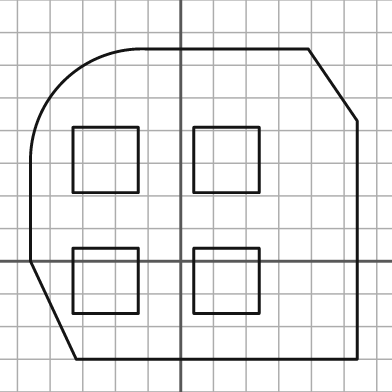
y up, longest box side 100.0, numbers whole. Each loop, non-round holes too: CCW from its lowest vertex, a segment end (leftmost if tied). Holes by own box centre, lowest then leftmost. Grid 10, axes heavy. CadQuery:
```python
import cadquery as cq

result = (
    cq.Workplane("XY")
    .moveTo(-32.0, -30.0)
    .lineTo(54.0, -30.0)
    .lineTo(54.0, 43.0)
    .lineTo(39.0, 65.0)
    .lineTo(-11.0, 65.0)
    .threePointArc((-36.0, 55.0), (-46.0, 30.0))
    .lineTo(-46.0, 0.0)
    .close()
    .moveTo(-33.0, -16.0)
    .lineTo(-13.0, -16.0)
    .lineTo(-13.0, 4.0)
    .lineTo(-33.0, 4.0)
    .close()
    .moveTo(4.0, -16.0)
    .lineTo(24.0, -16.0)
    .lineTo(24.0, 4.0)
    .lineTo(4.0, 4.0)
    .close()
    .moveTo(-33.0, 21.0)
    .lineTo(-13.0, 21.0)
    .lineTo(-13.0, 41.0)
    .lineTo(-33.0, 41.0)
    .close()
    .moveTo(4.0, 21.0)
    .lineTo(24.0, 21.0)
    .lineTo(24.0, 41.0)
    .lineTo(4.0, 41.0)
    .close()
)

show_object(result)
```